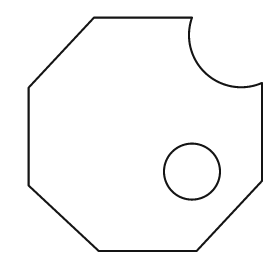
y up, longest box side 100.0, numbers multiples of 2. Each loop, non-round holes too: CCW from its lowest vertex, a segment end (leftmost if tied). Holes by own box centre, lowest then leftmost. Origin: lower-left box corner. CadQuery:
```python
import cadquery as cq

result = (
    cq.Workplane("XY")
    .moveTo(30.0, 0.0)
    .lineTo(72.0, 0.0)
    .lineTo(100.0, 30.0)
    .lineTo(100.0, 72.0)
    .threePointArc((76.0, 76.0), (70.0, 100.0))
    .lineTo(28.0, 100.0)
    .lineTo(0.0, 70.0)
    .lineTo(0.0, 28.0)
    .close()
    .moveTo(70.0, 34.0)
    .circle(12.0)
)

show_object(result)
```